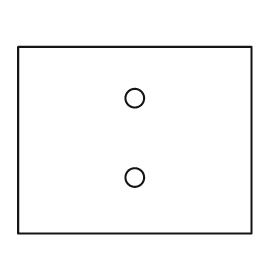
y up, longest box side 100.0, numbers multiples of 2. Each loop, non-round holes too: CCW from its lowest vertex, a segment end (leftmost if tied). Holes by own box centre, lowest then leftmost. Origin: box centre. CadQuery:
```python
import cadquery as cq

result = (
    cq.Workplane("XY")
    .moveTo(-50.0, -40.0)
    .lineTo(50.0, -40.0)
    .lineTo(50.0, 40.0)
    .lineTo(-50.0, 40.0)
    .close()
    .moveTo(0.0, -16.0)
    .circle(4.0)
    .moveTo(0.0, 18.0)
    .circle(4.0)
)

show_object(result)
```